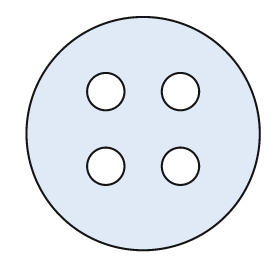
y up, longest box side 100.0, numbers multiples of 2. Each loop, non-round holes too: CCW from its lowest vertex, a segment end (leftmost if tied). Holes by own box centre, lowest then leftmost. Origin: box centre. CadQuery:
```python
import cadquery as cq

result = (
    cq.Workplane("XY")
    .moveTo(0.0, 0.0)
    .circle(50.0)
    .moveTo(-16.0, -14.0)
    .circle(8.0)
    .moveTo(16.0, -14.0)
    .circle(8.0)
    .moveTo(-16.0, 18.0)
    .circle(8.0)
    .moveTo(16.0, 18.0)
    .circle(8.0)
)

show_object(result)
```